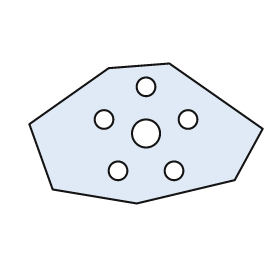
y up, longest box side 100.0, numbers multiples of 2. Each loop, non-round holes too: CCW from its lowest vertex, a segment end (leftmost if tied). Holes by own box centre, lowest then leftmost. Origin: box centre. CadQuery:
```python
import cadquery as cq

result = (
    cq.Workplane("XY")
    .moveTo(-4.0, -30.0)
    .lineTo(38.0, -20.0)
    .lineTo(50.0, 2.0)
    .lineTo(10.0, 30.0)
    .lineTo(-16.0, 28.0)
    .lineTo(-50.0, 4.0)
    .lineTo(-40.0, -24.0)
    .close()
    .moveTo(-12.0, -16.0)
    .circle(4.0)
    .moveTo(12.0, -16.0)
    .circle(4.0)
    .moveTo(0.0, 0.0)
    .circle(6.0)
    .moveTo(-18.0, 6.0)
    .circle(4.0)
    .moveTo(18.0, 6.0)
    .circle(4.0)
    .moveTo(0.0, 20.0)
    .circle(4.0)
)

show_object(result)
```